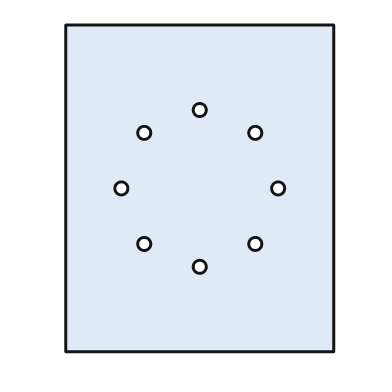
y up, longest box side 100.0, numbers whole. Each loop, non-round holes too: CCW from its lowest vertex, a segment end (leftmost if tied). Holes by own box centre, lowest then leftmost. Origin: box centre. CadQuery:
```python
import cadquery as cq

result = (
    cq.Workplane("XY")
    .moveTo(-41.0, -50.0)
    .lineTo(41.0, -50.0)
    .lineTo(41.0, 50.0)
    .lineTo(-41.0, 50.0)
    .close()
    .moveTo(0.0, -24.0)
    .circle(2.0)
    .moveTo(-17.0, -17.0)
    .circle(2.0)
    .moveTo(17.0, -17.0)
    .circle(2.0)
    .moveTo(-24.0, 0.0)
    .circle(2.0)
    .moveTo(24.0, 0.0)
    .circle(2.0)
    .moveTo(-17.0, 17.0)
    .circle(2.0)
    .moveTo(17.0, 17.0)
    .circle(2.0)
    .moveTo(0.0, 24.0)
    .circle(2.0)
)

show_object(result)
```